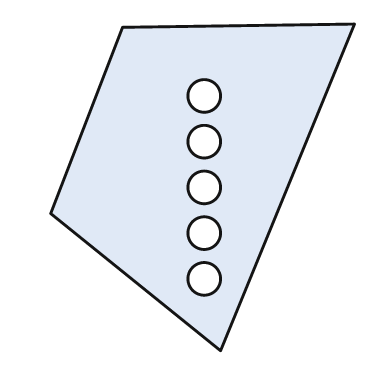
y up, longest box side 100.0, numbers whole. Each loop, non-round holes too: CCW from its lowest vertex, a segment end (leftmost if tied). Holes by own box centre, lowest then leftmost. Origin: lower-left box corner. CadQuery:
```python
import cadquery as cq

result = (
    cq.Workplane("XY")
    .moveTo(52.0, 0.0)
    .lineTo(93.0, 100.0)
    .lineTo(22.0, 99.0)
    .lineTo(0.0, 42.0)
    .close()
    .moveTo(47.0, 22.0)
    .circle(5.0)
    .moveTo(47.0, 36.0)
    .circle(5.0)
    .moveTo(47.0, 50.0)
    .circle(5.0)
    .moveTo(47.0, 64.0)
    .circle(5.0)
    .moveTo(47.0, 78.0)
    .circle(5.0)
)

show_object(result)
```